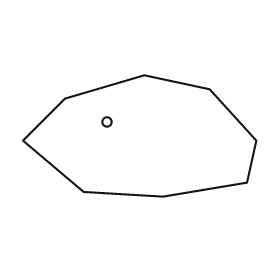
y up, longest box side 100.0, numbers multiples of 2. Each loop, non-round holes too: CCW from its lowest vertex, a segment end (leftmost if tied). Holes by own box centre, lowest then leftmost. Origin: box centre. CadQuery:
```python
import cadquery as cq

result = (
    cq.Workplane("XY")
    .moveTo(10.0, -26.0)
    .lineTo(46.0, -20.0)
    .lineTo(50.0, -2.0)
    .lineTo(30.0, 20.0)
    .lineTo(2.0, 26.0)
    .lineTo(-32.0, 16.0)
    .lineTo(-50.0, -2.0)
    .lineTo(-24.0, -24.0)
    .close()
    .moveTo(-14.0, 6.0)
    .circle(2.0)
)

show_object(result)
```